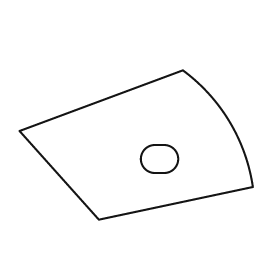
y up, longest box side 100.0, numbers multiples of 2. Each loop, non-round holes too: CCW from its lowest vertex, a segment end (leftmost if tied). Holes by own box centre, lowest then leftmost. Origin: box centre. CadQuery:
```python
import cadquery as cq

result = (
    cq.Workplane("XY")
    .moveTo(-16.0, -32.0)
    .lineTo(50.0, -18.0)
    .threePointArc((40.0, 10.0), (20.0, 32.0))
    .lineTo(-50.0, 6.0)
    .close()
    .moveTo(8.0, -12.0)
    .lineTo(12.0, -12.0)
    .threePointArc((18.0, -6.0), (12.0, 0.0))
    .lineTo(8.0, 0.0)
    .threePointArc((2.0, -6.0), (8.0, -12.0))
    .close()
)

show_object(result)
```